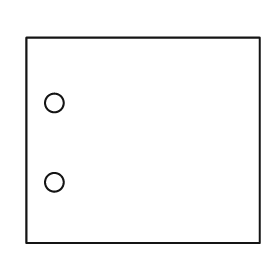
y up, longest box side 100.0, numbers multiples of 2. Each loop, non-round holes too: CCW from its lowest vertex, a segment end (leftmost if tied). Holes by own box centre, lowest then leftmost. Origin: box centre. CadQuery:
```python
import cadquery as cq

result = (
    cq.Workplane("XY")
    .moveTo(-50.0, -44.0)
    .lineTo(50.0, -44.0)
    .lineTo(50.0, 44.0)
    .lineTo(-50.0, 44.0)
    .close()
    .moveTo(-38.0, -18.0)
    .circle(4.0)
    .moveTo(-38.0, 16.0)
    .circle(4.0)
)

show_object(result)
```